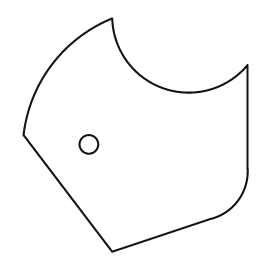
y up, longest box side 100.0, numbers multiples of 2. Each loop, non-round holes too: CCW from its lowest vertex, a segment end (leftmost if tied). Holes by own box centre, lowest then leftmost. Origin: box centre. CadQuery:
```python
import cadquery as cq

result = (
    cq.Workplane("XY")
    .moveTo(-10.0, -50.0)
    .lineTo(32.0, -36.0)
    .threePointArc((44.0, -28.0), (48.0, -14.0))
    .lineTo(48.0, 30.0)
    .threePointArc((12.0, 20.0), (-10.0, 50.0))
    .threePointArc((-36.0, 30.0), (-48.0, 0.0))
    .close()
    .moveTo(-20.0, -4.0)
    .circle(4.0)
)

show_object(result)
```